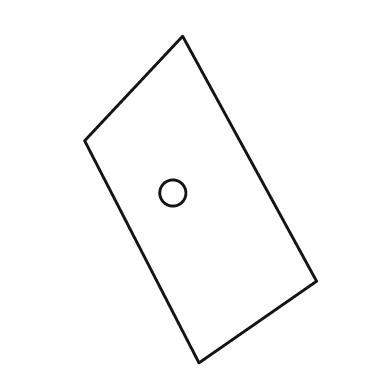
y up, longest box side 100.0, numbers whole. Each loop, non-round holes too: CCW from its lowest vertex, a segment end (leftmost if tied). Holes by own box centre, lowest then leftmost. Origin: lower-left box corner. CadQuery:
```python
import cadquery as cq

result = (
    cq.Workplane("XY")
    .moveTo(35.0, 0.0)
    .lineTo(71.0, 25.0)
    .lineTo(30.0, 100.0)
    .lineTo(0.0, 68.0)
    .close()
    .moveTo(27.0, 52.0)
    .circle(4.0)
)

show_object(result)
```